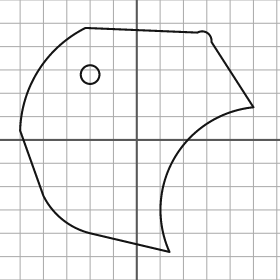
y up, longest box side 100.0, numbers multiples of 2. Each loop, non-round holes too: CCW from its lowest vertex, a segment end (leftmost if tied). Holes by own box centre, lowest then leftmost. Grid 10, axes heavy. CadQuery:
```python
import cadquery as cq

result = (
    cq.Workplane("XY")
    .moveTo(14.0, -48.0)
    .threePointArc((16.0, -8.0), (50.0, 14.0))
    .lineTo(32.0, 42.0)
    .threePointArc((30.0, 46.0), (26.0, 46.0))
    .lineTo(-22.0, 48.0)
    .threePointArc((-42.0, 30.0), (-50.0, 4.0))
    .lineTo(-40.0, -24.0)
    .threePointArc((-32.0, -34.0), (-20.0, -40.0))
    .close()
    .moveTo(-20.0, 28.0)
    .circle(4.0)
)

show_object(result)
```